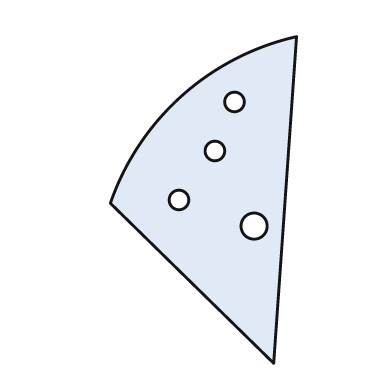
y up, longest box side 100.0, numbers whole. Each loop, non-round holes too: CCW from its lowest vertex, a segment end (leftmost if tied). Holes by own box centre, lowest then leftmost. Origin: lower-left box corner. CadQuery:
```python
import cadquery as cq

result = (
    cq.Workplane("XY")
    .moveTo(50.0, 0.0)
    .lineTo(57.0, 100.0)
    .threePointArc((22.0, 82.0), (0.0, 49.0))
    .close()
    .moveTo(44.0, 42.0)
    .circle(4.0)
    .moveTo(21.0, 50.0)
    .circle(3.0)
    .moveTo(32.0, 65.0)
    .circle(3.0)
    .moveTo(38.0, 80.0)
    .circle(3.0)
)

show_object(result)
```